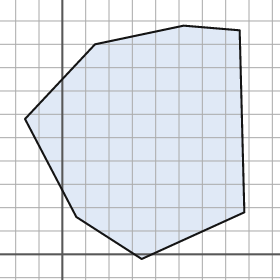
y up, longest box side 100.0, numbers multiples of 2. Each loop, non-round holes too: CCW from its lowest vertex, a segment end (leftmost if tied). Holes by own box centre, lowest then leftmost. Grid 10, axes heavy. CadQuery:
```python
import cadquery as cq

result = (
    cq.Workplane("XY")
    .moveTo(34.0, -2.0)
    .lineTo(78.0, 18.0)
    .lineTo(76.0, 96.0)
    .lineTo(52.0, 98.0)
    .lineTo(14.0, 90.0)
    .lineTo(-16.0, 58.0)
    .lineTo(6.0, 16.0)
    .close()
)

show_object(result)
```